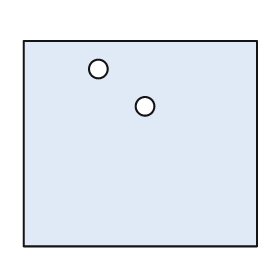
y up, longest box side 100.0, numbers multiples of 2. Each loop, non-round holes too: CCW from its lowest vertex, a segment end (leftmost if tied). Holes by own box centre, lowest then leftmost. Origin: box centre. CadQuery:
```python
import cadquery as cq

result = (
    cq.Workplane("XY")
    .moveTo(-50.0, -44.0)
    .lineTo(50.0, -44.0)
    .lineTo(50.0, 44.0)
    .lineTo(-50.0, 44.0)
    .close()
    .moveTo(2.0, 16.0)
    .circle(4.0)
    .moveTo(-18.0, 32.0)
    .circle(4.0)
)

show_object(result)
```